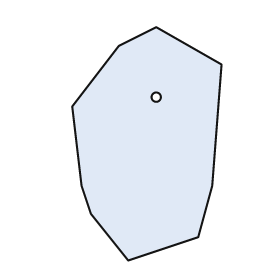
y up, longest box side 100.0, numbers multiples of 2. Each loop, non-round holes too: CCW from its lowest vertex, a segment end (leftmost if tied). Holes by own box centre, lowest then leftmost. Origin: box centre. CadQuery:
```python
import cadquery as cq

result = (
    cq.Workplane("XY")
    .moveTo(-8.0, -50.0)
    .lineTo(22.0, -40.0)
    .lineTo(28.0, -18.0)
    .lineTo(32.0, 34.0)
    .lineTo(4.0, 50.0)
    .lineTo(-12.0, 42.0)
    .lineTo(-32.0, 16.0)
    .lineTo(-28.0, -18.0)
    .lineTo(-24.0, -30.0)
    .close()
    .moveTo(4.0, 20.0)
    .circle(2.0)
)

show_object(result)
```